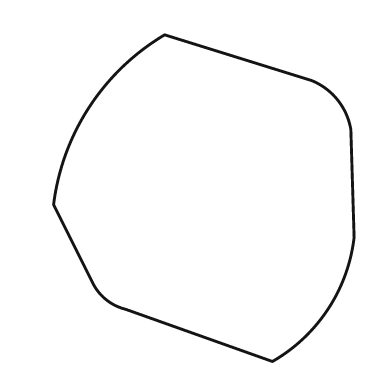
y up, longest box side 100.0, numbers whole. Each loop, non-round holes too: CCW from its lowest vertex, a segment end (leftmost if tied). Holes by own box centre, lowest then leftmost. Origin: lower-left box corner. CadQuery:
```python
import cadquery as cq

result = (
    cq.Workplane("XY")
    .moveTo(67.0, 0.0)
    .threePointArc((84.0, 16.0), (92.0, 38.0))
    .lineTo(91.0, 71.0)
    .threePointArc((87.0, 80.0), (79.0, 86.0))
    .lineTo(34.0, 100.0)
    .threePointArc((11.0, 78.0), (0.0, 48.0))
    .lineTo(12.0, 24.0)
    .threePointArc((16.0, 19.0), (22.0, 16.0))
    .close()
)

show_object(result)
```